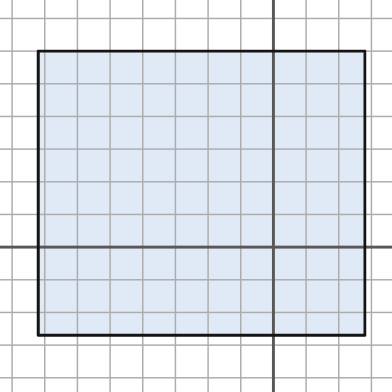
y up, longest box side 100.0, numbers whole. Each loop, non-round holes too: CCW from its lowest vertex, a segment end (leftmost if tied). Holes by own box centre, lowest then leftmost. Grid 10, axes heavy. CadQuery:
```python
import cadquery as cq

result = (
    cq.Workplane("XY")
    .moveTo(-72.0, -27.0)
    .lineTo(28.0, -27.0)
    .lineTo(28.0, 60.0)
    .lineTo(-72.0, 60.0)
    .close()
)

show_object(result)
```